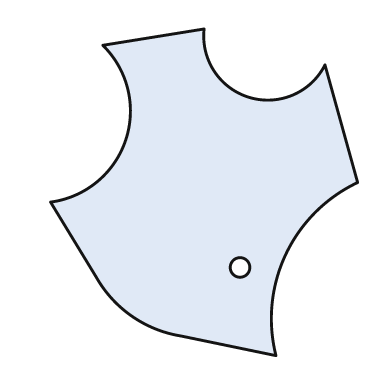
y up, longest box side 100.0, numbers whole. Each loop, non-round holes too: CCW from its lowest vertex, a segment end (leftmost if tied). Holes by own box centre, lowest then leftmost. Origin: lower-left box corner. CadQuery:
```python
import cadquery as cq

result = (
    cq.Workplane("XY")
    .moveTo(69.0, 0.0)
    .threePointArc((72.0, 31.0), (94.0, 53.0))
    .lineTo(84.0, 89.0)
    .threePointArc((61.0, 79.0), (47.0, 100.0))
    .lineTo(16.0, 95.0)
    .threePointArc((23.0, 66.0), (0.0, 47.0))
    .lineTo(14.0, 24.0)
    .threePointArc((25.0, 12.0), (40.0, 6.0))
    .close()
    .moveTo(58.0, 27.0)
    .circle(3.0)
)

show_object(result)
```